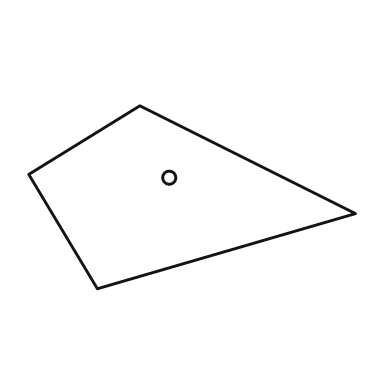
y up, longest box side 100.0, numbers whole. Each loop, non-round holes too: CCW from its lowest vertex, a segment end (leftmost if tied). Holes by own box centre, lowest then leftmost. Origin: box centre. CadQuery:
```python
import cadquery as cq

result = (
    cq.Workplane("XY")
    .moveTo(-29.0, -28.0)
    .lineTo(50.0, -5.0)
    .lineTo(-16.0, 28.0)
    .lineTo(-50.0, 7.0)
    .close()
    .moveTo(-7.0, 6.0)
    .circle(2.0)
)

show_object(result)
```